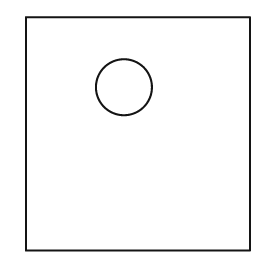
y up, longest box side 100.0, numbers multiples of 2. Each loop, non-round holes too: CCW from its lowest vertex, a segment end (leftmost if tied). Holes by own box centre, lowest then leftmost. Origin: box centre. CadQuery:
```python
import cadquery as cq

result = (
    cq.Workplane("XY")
    .moveTo(-48.0, -50.0)
    .lineTo(48.0, -50.0)
    .lineTo(48.0, 50.0)
    .lineTo(-48.0, 50.0)
    .close()
    .moveTo(-6.0, 20.0)
    .circle(12.0)
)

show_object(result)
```